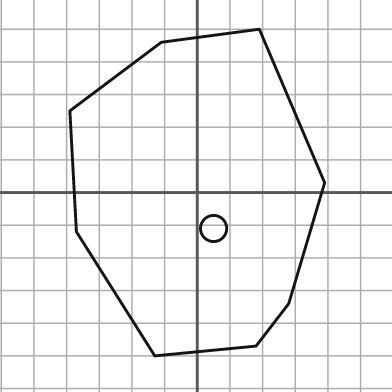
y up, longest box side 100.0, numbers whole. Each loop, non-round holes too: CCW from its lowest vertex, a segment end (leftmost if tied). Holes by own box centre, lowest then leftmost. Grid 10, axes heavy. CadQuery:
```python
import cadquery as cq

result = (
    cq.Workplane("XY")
    .moveTo(-13.0, -50.0)
    .lineTo(18.0, -47.0)
    .lineTo(28.0, -34.0)
    .lineTo(39.0, 3.0)
    .lineTo(19.0, 50.0)
    .lineTo(-11.0, 46.0)
    .lineTo(-39.0, 25.0)
    .lineTo(-37.0, -12.0)
    .close()
    .moveTo(5.0, -11.0)
    .circle(4.0)
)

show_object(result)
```